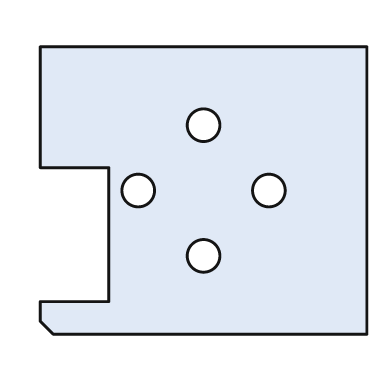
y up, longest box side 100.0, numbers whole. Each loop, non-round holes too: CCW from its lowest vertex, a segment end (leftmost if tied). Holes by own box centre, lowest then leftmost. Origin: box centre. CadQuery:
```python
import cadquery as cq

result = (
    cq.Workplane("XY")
    .moveTo(-46.0, -44.0)
    .lineTo(50.0, -44.0)
    .lineTo(50.0, 44.0)
    .lineTo(-50.0, 44.0)
    .lineTo(-50.0, 7.0)
    .lineTo(-29.0, 7.0)
    .lineTo(-29.0, -34.0)
    .lineTo(-50.0, -34.0)
    .lineTo(-50.0, -40.0)
    .close()
    .moveTo(0.0, -20.0)
    .circle(5.0)
    .moveTo(-20.0, 0.0)
    .circle(5.0)
    .moveTo(20.0, 0.0)
    .circle(5.0)
    .moveTo(0.0, 20.0)
    .circle(5.0)
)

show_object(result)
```